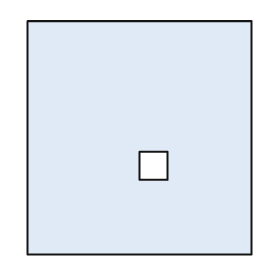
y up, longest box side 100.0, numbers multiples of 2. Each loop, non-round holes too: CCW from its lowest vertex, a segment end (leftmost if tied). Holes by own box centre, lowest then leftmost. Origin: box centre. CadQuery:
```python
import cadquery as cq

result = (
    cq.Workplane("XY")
    .moveTo(-48.0, -50.0)
    .lineTo(48.0, -50.0)
    .lineTo(48.0, 50.0)
    .lineTo(-48.0, 50.0)
    .close()
    .moveTo(0.0, -18.0)
    .lineTo(12.0, -18.0)
    .lineTo(12.0, -6.0)
    .lineTo(0.0, -6.0)
    .close()
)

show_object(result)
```